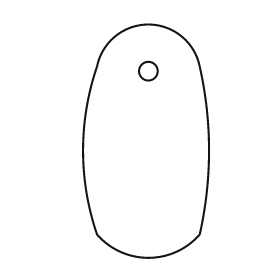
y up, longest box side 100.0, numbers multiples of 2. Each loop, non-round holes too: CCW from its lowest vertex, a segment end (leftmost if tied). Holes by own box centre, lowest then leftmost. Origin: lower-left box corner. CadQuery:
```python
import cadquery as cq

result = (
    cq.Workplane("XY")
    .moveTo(6.0, 10.0)
    .threePointArc((28.0, 0.0), (50.0, 10.0))
    .threePointArc((54.0, 46.0), (50.0, 82.0))
    .threePointArc((28.0, 100.0), (6.0, 82.0))
    .threePointArc((0.0, 46.0), (6.0, 10.0))
    .close()
    .moveTo(28.0, 80.0)
    .circle(4.0)
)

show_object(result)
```